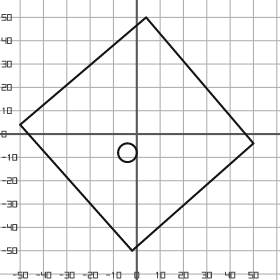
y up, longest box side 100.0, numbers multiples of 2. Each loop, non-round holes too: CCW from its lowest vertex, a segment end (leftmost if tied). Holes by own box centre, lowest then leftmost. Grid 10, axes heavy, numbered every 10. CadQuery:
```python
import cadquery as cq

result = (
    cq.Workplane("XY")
    .moveTo(-2.0, -50.0)
    .lineTo(50.0, -4.0)
    .lineTo(4.0, 50.0)
    .lineTo(-50.0, 4.0)
    .close()
    .moveTo(-4.0, -8.0)
    .circle(4.0)
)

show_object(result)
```